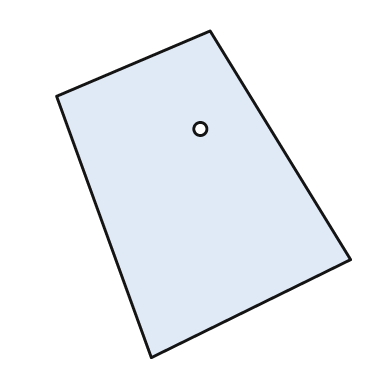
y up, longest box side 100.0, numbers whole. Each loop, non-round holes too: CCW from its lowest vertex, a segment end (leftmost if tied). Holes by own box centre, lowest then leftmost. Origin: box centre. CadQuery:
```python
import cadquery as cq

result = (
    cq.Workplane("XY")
    .moveTo(-16.0, -50.0)
    .lineTo(45.0, -20.0)
    .lineTo(2.0, 50.0)
    .lineTo(-45.0, 30.0)
    .close()
    .moveTo(-1.0, 20.0)
    .circle(2.0)
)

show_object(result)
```